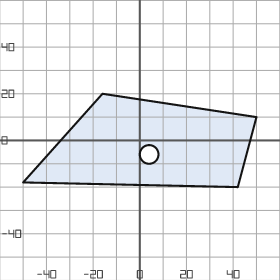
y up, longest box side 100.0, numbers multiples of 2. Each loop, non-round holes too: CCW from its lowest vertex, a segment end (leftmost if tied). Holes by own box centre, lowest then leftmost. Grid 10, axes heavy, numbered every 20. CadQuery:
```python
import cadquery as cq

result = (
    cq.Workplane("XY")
    .moveTo(42.0, -20.0)
    .lineTo(50.0, 10.0)
    .lineTo(-16.0, 20.0)
    .lineTo(-50.0, -18.0)
    .close()
    .moveTo(4.0, -6.0)
    .circle(4.0)
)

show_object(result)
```